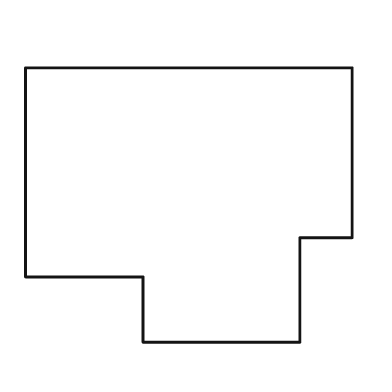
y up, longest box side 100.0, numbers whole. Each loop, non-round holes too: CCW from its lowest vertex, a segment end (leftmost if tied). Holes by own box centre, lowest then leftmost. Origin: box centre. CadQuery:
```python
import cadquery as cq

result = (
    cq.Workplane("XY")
    .moveTo(-14.0, -42.0)
    .lineTo(34.0, -42.0)
    .lineTo(34.0, -10.0)
    .lineTo(50.0, -10.0)
    .lineTo(50.0, 42.0)
    .lineTo(-50.0, 42.0)
    .lineTo(-50.0, -22.0)
    .lineTo(-14.0, -22.0)
    .close()
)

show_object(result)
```